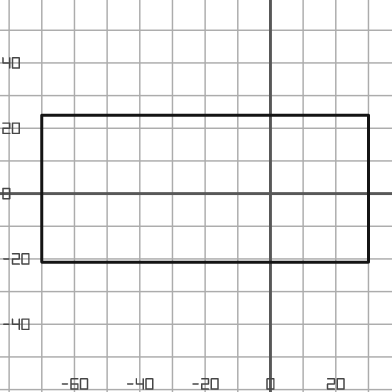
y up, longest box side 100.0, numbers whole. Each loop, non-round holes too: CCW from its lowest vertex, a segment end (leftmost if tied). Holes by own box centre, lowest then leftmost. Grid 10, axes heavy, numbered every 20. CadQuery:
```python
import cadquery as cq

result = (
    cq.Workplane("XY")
    .moveTo(-70.0, -21.0)
    .lineTo(30.0, -21.0)
    .lineTo(30.0, 24.0)
    .lineTo(-70.0, 24.0)
    .close()
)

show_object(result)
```